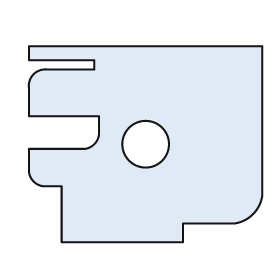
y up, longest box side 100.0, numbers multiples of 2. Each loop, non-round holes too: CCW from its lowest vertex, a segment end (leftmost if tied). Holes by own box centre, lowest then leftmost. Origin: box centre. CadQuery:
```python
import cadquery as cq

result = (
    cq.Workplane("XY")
    .moveTo(-36.0, -42.0)
    .lineTo(16.0, -42.0)
    .lineTo(16.0, -34.0)
    .lineTo(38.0, -34.0)
    .threePointArc((46.0, -30.0), (50.0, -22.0))
    .lineTo(50.0, 42.0)
    .lineTo(-50.0, 42.0)
    .lineTo(-50.0, 36.0)
    .lineTo(-22.0, 36.0)
    .lineTo(-22.0, 32.0)
    .lineTo(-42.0, 32.0)
    .threePointArc((-48.0, 30.0), (-50.0, 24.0))
    .lineTo(-50.0, 12.0)
    .lineTo(-20.0, 12.0)
    .lineTo(-20.0, 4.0)
    .threePointArc((-22.0, 0.0), (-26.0, -2.0))
    .lineTo(-50.0, -2.0)
    .lineTo(-50.0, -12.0)
    .threePointArc((-48.0, -16.0), (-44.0, -18.0))
    .lineTo(-36.0, -18.0)
    .close()
    .moveTo(0.0, 0.0)
    .circle(10.0)
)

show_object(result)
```